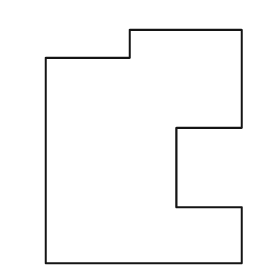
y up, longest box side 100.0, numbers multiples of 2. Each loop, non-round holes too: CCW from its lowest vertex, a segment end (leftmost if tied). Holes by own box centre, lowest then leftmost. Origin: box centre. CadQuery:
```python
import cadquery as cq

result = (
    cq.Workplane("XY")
    .moveTo(-42.0, -50.0)
    .lineTo(42.0, -50.0)
    .lineTo(42.0, -26.0)
    .lineTo(14.0, -26.0)
    .lineTo(14.0, 8.0)
    .lineTo(42.0, 8.0)
    .lineTo(42.0, 50.0)
    .lineTo(-6.0, 50.0)
    .lineTo(-6.0, 38.0)
    .lineTo(-42.0, 38.0)
    .close()
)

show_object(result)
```